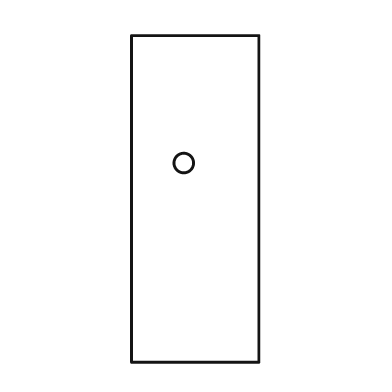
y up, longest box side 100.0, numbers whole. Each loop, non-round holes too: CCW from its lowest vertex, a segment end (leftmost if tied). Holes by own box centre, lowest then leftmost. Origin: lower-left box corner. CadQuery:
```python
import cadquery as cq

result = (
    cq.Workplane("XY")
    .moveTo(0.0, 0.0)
    .lineTo(39.0, 0.0)
    .lineTo(39.0, 100.0)
    .lineTo(0.0, 100.0)
    .close()
    .moveTo(16.0, 61.0)
    .circle(3.0)
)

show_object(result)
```